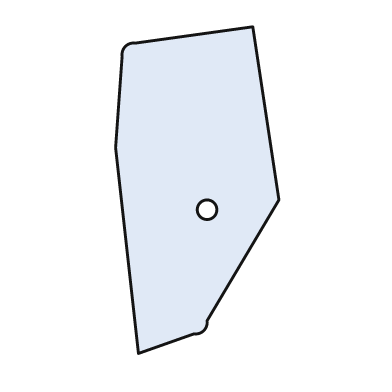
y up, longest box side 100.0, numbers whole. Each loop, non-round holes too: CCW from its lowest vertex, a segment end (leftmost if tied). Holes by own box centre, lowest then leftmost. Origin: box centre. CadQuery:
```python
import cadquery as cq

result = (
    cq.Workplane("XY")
    .moveTo(-18.0, -50.0)
    .lineTo(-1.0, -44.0)
    .threePointArc((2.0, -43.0), (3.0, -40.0))
    .lineTo(25.0, -3.0)
    .lineTo(17.0, 50.0)
    .lineTo(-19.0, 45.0)
    .threePointArc((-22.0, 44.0), (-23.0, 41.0))
    .lineTo(-25.0, 13.0)
    .close()
    .moveTo(3.0, -6.0)
    .circle(3.0)
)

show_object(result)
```